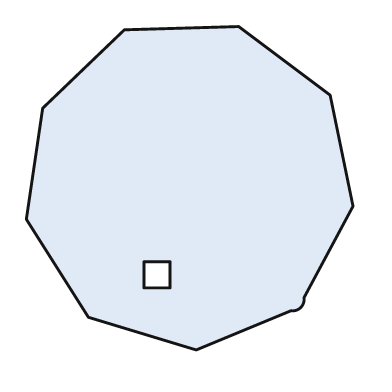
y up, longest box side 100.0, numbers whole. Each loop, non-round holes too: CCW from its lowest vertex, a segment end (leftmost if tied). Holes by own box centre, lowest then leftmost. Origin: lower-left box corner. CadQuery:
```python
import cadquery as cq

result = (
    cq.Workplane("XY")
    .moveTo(52.0, 0.0)
    .lineTo(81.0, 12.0)
    .threePointArc((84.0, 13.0), (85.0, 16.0))
    .lineTo(100.0, 44.0)
    .lineTo(93.0, 78.0)
    .lineTo(65.0, 99.0)
    .lineTo(30.0, 98.0)
    .lineTo(5.0, 74.0)
    .lineTo(0.0, 40.0)
    .lineTo(19.0, 10.0)
    .close()
    .moveTo(36.0, 19.0)
    .lineTo(44.0, 19.0)
    .lineTo(44.0, 27.0)
    .lineTo(36.0, 27.0)
    .close()
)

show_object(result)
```